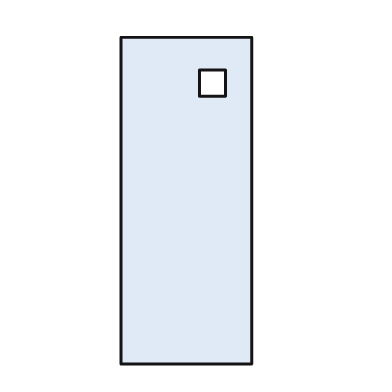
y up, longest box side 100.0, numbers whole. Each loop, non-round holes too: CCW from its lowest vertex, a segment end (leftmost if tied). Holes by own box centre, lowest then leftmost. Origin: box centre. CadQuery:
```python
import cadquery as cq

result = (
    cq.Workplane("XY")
    .moveTo(-20.0, -50.0)
    .lineTo(20.0, -50.0)
    .lineTo(20.0, 50.0)
    .lineTo(-20.0, 50.0)
    .close()
    .moveTo(4.0, 32.0)
    .lineTo(12.0, 32.0)
    .lineTo(12.0, 40.0)
    .lineTo(4.0, 40.0)
    .close()
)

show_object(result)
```